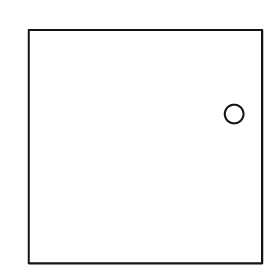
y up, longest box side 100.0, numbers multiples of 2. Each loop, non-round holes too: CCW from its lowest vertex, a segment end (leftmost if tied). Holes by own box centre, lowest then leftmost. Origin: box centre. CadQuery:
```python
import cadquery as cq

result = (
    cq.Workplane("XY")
    .moveTo(-50.0, -50.0)
    .lineTo(50.0, -50.0)
    .lineTo(50.0, 50.0)
    .lineTo(-50.0, 50.0)
    .close()
    .moveTo(38.0, 14.0)
    .circle(4.0)
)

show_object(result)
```